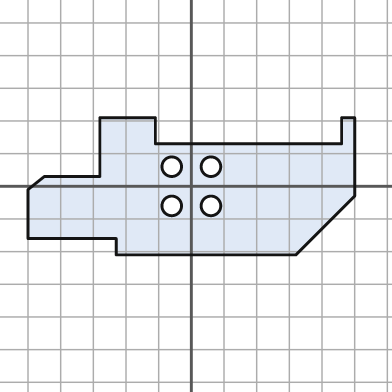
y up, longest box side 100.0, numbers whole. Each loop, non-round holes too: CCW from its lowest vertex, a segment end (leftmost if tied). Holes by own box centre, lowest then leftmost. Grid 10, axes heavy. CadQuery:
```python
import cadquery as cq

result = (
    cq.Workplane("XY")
    .moveTo(-23.0, -21.0)
    .lineTo(32.0, -21.0)
    .lineTo(50.0, -3.0)
    .lineTo(50.0, 21.0)
    .lineTo(46.0, 21.0)
    .lineTo(46.0, 13.0)
    .lineTo(-11.0, 13.0)
    .lineTo(-11.0, 21.0)
    .lineTo(-28.0, 21.0)
    .lineTo(-28.0, 3.0)
    .lineTo(-45.0, 3.0)
    .lineTo(-50.0, -1.0)
    .lineTo(-50.0, -16.0)
    .lineTo(-23.0, -16.0)
    .close()
    .moveTo(-6.0, -6.0)
    .circle(3.0)
    .moveTo(6.0, -6.0)
    .circle(3.0)
    .moveTo(-6.0, 6.0)
    .circle(3.0)
    .moveTo(6.0, 6.0)
    .circle(3.0)
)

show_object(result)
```